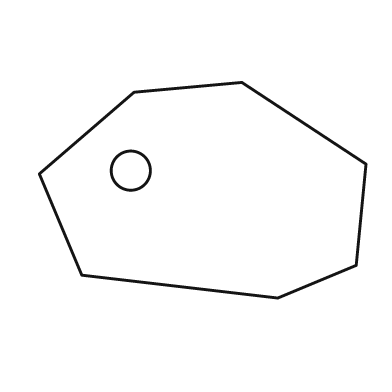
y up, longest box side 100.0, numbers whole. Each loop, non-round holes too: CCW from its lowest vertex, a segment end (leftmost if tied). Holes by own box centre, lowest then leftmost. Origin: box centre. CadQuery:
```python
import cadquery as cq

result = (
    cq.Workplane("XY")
    .moveTo(23.0, -33.0)
    .lineTo(47.0, -23.0)
    .lineTo(50.0, 8.0)
    .lineTo(12.0, 33.0)
    .lineTo(-21.0, 30.0)
    .lineTo(-50.0, 5.0)
    .lineTo(-37.0, -26.0)
    .close()
    .moveTo(-22.0, 6.0)
    .circle(6.0)
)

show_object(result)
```